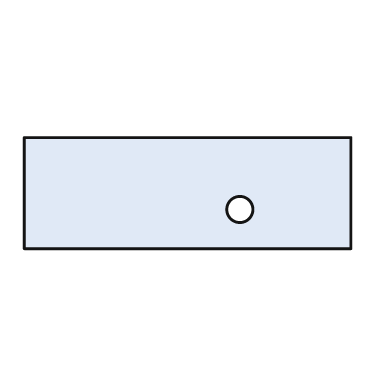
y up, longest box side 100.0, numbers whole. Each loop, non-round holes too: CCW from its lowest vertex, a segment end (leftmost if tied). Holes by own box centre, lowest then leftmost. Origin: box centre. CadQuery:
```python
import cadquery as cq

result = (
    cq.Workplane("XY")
    .moveTo(-50.0, -17.0)
    .lineTo(50.0, -17.0)
    .lineTo(50.0, 17.0)
    .lineTo(-50.0, 17.0)
    .close()
    .moveTo(16.0, -5.0)
    .circle(4.0)
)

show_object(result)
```